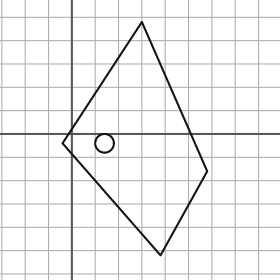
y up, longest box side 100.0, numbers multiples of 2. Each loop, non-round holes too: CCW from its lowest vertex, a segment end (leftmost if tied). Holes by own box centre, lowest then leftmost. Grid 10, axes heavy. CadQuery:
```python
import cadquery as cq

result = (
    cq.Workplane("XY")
    .moveTo(38.0, -52.0)
    .lineTo(58.0, -16.0)
    .lineTo(30.0, 48.0)
    .lineTo(-4.0, -4.0)
    .close()
    .moveTo(14.0, -4.0)
    .circle(4.0)
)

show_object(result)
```